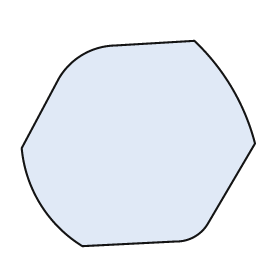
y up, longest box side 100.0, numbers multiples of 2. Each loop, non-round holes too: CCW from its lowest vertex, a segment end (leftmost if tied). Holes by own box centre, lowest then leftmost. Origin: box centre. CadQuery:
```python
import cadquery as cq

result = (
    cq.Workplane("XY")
    .moveTo(-24.0, -44.0)
    .lineTo(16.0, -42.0)
    .threePointArc((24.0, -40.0), (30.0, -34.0))
    .lineTo(50.0, 0.0)
    .threePointArc((40.0, 24.0), (24.0, 44.0))
    .lineTo(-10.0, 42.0)
    .threePointArc((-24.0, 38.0), (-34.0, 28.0))
    .lineTo(-50.0, -2.0)
    .threePointArc((-42.0, -26.0), (-24.0, -44.0))
    .close()
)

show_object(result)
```